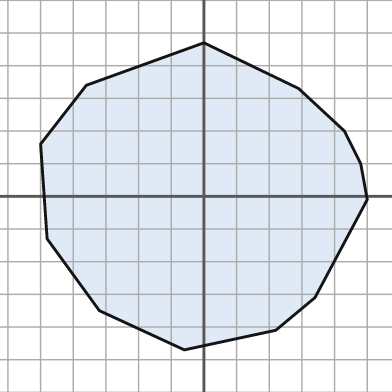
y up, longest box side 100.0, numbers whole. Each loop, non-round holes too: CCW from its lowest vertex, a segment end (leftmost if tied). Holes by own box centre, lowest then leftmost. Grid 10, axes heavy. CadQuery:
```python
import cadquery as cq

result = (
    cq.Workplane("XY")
    .moveTo(-6.0, -47.0)
    .lineTo(22.0, -41.0)
    .lineTo(34.0, -31.0)
    .lineTo(50.0, -1.0)
    .lineTo(48.0, 10.0)
    .lineTo(43.0, 20.0)
    .lineTo(29.0, 33.0)
    .lineTo(0.0, 47.0)
    .lineTo(-36.0, 34.0)
    .lineTo(-50.0, 16.0)
    .lineTo(-48.0, -13.0)
    .lineTo(-32.0, -35.0)
    .close()
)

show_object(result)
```